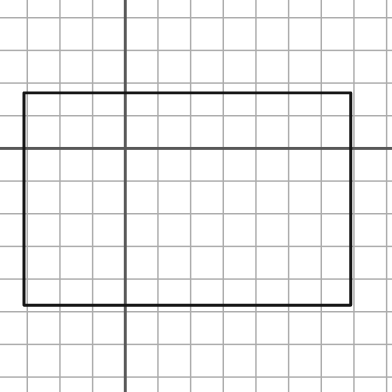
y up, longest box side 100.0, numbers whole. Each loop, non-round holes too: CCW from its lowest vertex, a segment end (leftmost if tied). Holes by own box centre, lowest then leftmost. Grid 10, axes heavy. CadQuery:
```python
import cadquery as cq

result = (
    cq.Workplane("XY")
    .moveTo(-31.0, -48.0)
    .lineTo(69.0, -48.0)
    .lineTo(69.0, 17.0)
    .lineTo(-31.0, 17.0)
    .close()
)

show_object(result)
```